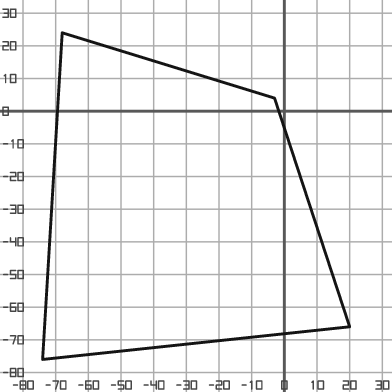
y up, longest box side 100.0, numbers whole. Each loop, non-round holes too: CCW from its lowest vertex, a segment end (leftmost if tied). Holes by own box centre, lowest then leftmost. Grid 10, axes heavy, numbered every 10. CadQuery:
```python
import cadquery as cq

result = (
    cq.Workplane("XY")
    .moveTo(-74.0, -76.0)
    .lineTo(20.0, -66.0)
    .lineTo(-3.0, 4.0)
    .lineTo(-68.0, 24.0)
    .close()
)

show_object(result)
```